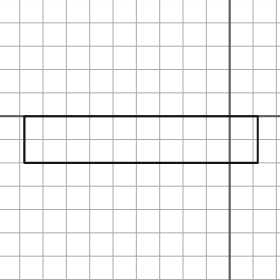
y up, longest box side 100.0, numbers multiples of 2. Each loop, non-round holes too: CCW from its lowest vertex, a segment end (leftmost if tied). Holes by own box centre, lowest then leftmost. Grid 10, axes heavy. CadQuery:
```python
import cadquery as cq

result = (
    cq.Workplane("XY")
    .moveTo(-88.0, -20.0)
    .lineTo(12.0, -20.0)
    .lineTo(12.0, 0.0)
    .lineTo(-88.0, 0.0)
    .close()
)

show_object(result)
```